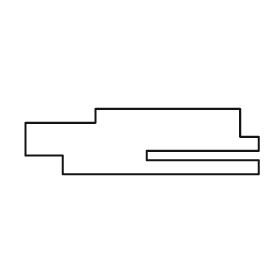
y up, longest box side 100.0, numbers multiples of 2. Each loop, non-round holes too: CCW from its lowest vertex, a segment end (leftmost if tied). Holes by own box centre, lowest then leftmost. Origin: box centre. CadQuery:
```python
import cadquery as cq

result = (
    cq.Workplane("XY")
    .moveTo(-34.0, -14.0)
    .lineTo(50.0, -14.0)
    .lineTo(50.0, -8.0)
    .lineTo(2.0, -8.0)
    .lineTo(2.0, -4.0)
    .lineTo(50.0, -4.0)
    .lineTo(50.0, 2.0)
    .lineTo(42.0, 2.0)
    .lineTo(42.0, 14.0)
    .lineTo(-20.0, 14.0)
    .lineTo(-20.0, 8.0)
    .lineTo(-50.0, 8.0)
    .lineTo(-50.0, -6.0)
    .lineTo(-34.0, -6.0)
    .close()
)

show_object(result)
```